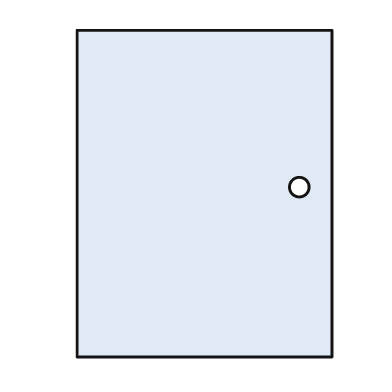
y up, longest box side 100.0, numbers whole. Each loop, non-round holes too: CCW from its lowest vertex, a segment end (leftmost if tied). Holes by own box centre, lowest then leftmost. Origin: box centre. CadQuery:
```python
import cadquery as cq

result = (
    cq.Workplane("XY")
    .moveTo(-39.0, -50.0)
    .lineTo(39.0, -50.0)
    .lineTo(39.0, 50.0)
    .lineTo(-39.0, 50.0)
    .close()
    .moveTo(29.0, 2.0)
    .circle(3.0)
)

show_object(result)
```